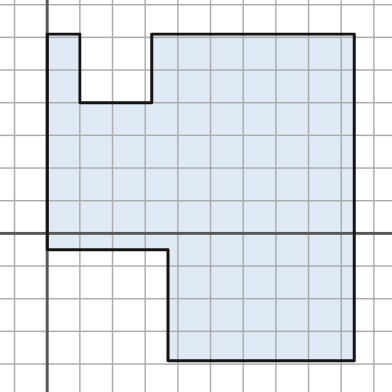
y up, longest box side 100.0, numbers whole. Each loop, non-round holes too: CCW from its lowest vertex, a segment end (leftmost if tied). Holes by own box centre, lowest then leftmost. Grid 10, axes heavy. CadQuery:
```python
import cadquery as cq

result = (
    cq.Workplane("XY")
    .moveTo(37.0, -39.0)
    .lineTo(94.0, -39.0)
    .lineTo(94.0, 61.0)
    .lineTo(32.0, 61.0)
    .lineTo(32.0, 40.0)
    .lineTo(10.0, 40.0)
    .lineTo(10.0, 61.0)
    .lineTo(0.0, 61.0)
    .lineTo(0.0, -5.0)
    .lineTo(37.0, -5.0)
    .close()
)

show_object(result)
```